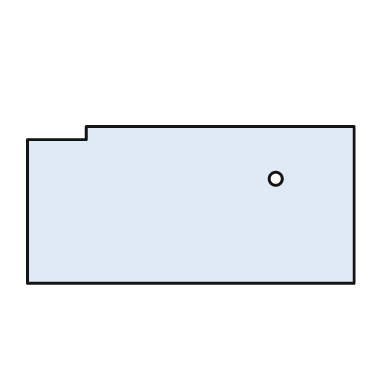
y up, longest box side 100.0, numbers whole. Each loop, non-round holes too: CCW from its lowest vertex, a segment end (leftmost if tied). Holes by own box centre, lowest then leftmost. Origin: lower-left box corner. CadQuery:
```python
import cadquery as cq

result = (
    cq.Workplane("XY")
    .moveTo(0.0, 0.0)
    .lineTo(100.0, 0.0)
    .lineTo(100.0, 48.0)
    .lineTo(18.0, 48.0)
    .lineTo(18.0, 44.0)
    .lineTo(0.0, 44.0)
    .close()
    .moveTo(76.0, 32.0)
    .circle(2.0)
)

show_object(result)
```